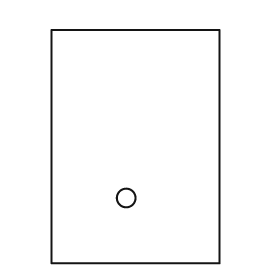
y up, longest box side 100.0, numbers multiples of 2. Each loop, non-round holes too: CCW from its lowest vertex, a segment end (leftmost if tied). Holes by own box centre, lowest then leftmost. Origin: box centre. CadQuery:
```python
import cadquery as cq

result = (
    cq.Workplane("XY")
    .moveTo(-36.0, -50.0)
    .lineTo(36.0, -50.0)
    .lineTo(36.0, 50.0)
    .lineTo(-36.0, 50.0)
    .close()
    .moveTo(-4.0, -22.0)
    .circle(4.0)
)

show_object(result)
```